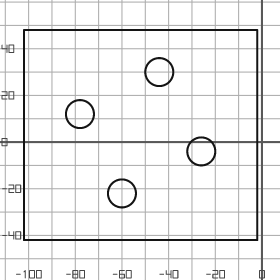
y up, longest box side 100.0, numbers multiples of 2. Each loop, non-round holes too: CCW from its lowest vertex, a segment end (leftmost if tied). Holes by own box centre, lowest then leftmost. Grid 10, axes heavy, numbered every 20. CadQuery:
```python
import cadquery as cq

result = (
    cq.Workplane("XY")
    .moveTo(-102.0, -42.0)
    .lineTo(-2.0, -42.0)
    .lineTo(-2.0, 48.0)
    .lineTo(-102.0, 48.0)
    .close()
    .moveTo(-60.0, -22.0)
    .circle(6.0)
    .moveTo(-26.0, -4.0)
    .circle(6.0)
    .moveTo(-78.0, 12.0)
    .circle(6.0)
    .moveTo(-44.0, 30.0)
    .circle(6.0)
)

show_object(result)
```